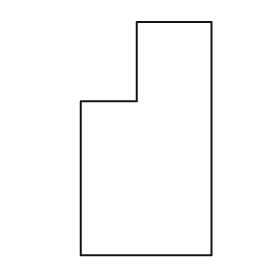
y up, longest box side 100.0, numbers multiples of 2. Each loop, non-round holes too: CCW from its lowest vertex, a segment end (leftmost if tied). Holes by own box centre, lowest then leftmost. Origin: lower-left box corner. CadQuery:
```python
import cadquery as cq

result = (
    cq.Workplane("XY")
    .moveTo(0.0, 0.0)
    .lineTo(56.0, 0.0)
    .lineTo(56.0, 100.0)
    .lineTo(24.0, 100.0)
    .lineTo(24.0, 66.0)
    .lineTo(0.0, 66.0)
    .close()
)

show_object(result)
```